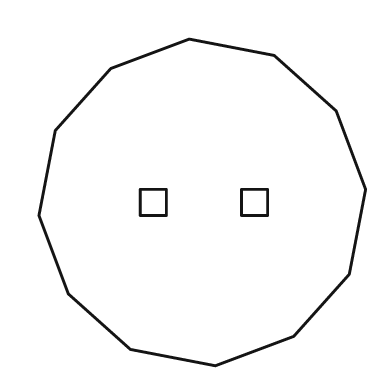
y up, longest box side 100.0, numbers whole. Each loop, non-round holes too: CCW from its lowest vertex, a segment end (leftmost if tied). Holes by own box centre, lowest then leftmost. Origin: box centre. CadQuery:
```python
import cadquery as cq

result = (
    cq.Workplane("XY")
    .moveTo(4.0, -50.0)
    .lineTo(28.0, -41.0)
    .lineTo(45.0, -22.0)
    .lineTo(50.0, 4.0)
    .lineTo(41.0, 28.0)
    .lineTo(22.0, 45.0)
    .lineTo(-4.0, 50.0)
    .lineTo(-28.0, 41.0)
    .lineTo(-45.0, 22.0)
    .lineTo(-50.0, -4.0)
    .lineTo(-41.0, -28.0)
    .lineTo(-22.0, -45.0)
    .close()
    .moveTo(-19.0, -4.0)
    .lineTo(-11.0, -4.0)
    .lineTo(-11.0, 4.0)
    .lineTo(-19.0, 4.0)
    .close()
    .moveTo(12.0, -4.0)
    .lineTo(20.0, -4.0)
    .lineTo(20.0, 4.0)
    .lineTo(12.0, 4.0)
    .close()
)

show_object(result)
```